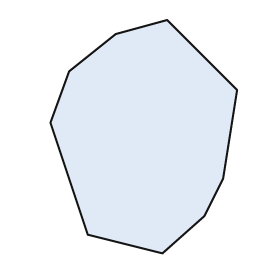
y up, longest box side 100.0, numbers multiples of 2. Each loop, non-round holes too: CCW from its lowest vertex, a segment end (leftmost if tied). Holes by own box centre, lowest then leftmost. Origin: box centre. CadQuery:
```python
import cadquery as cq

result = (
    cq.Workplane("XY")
    .moveTo(8.0, -50.0)
    .lineTo(26.0, -34.0)
    .lineTo(34.0, -18.0)
    .lineTo(40.0, 20.0)
    .lineTo(10.0, 50.0)
    .lineTo(-12.0, 44.0)
    .lineTo(-32.0, 28.0)
    .lineTo(-40.0, 6.0)
    .lineTo(-24.0, -42.0)
    .close()
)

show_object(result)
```